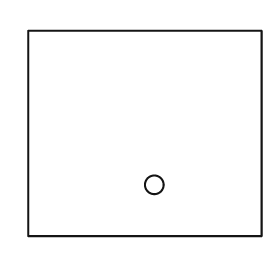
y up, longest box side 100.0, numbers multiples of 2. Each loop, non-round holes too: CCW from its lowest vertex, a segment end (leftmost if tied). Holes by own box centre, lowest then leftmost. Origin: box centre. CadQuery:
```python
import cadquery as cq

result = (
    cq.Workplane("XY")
    .moveTo(-50.0, -44.0)
    .lineTo(50.0, -44.0)
    .lineTo(50.0, 44.0)
    .lineTo(-50.0, 44.0)
    .close()
    .moveTo(4.0, -22.0)
    .circle(4.0)
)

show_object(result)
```